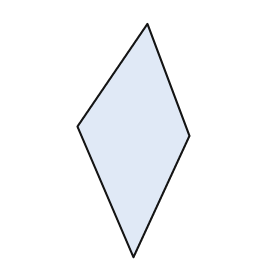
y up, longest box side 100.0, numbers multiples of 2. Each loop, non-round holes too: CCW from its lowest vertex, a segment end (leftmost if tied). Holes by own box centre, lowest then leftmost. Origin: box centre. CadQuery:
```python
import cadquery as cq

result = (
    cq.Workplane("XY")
    .moveTo(0.0, -50.0)
    .lineTo(24.0, 2.0)
    .lineTo(6.0, 50.0)
    .lineTo(-24.0, 6.0)
    .close()
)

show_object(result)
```